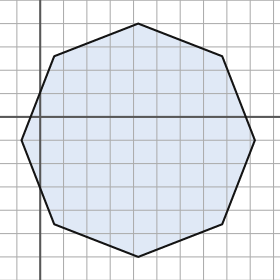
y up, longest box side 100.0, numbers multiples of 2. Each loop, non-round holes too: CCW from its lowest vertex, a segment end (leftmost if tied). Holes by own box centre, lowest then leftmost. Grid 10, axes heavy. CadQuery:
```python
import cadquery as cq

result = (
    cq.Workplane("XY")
    .moveTo(42.0, -60.0)
    .lineTo(78.0, -46.0)
    .lineTo(92.0, -10.0)
    .lineTo(78.0, 26.0)
    .lineTo(42.0, 40.0)
    .lineTo(6.0, 26.0)
    .lineTo(-8.0, -10.0)
    .lineTo(6.0, -46.0)
    .close()
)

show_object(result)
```